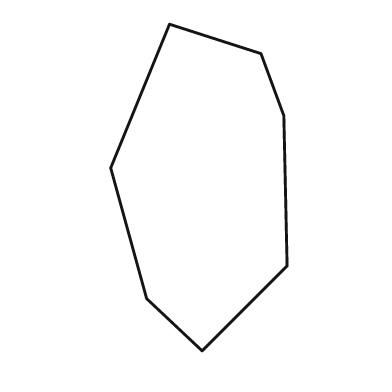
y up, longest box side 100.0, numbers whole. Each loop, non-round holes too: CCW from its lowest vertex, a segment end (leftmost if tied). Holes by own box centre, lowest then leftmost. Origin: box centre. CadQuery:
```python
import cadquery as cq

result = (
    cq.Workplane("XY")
    .moveTo(1.0, -50.0)
    .lineTo(27.0, -24.0)
    .lineTo(26.0, 22.0)
    .lineTo(19.0, 41.0)
    .lineTo(-9.0, 50.0)
    .lineTo(-27.0, 6.0)
    .lineTo(-16.0, -34.0)
    .close()
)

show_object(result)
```